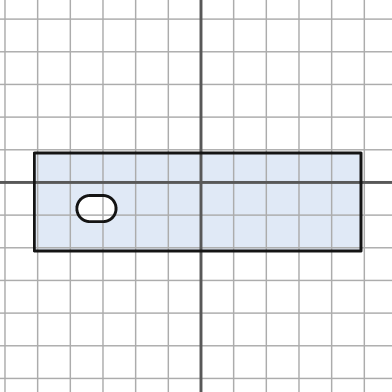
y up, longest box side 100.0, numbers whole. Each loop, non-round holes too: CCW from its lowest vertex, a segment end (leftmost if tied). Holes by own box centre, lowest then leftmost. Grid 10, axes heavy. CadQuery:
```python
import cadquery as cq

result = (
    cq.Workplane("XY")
    .moveTo(-51.0, -21.0)
    .lineTo(49.0, -21.0)
    .lineTo(49.0, 9.0)
    .lineTo(-51.0, 9.0)
    .close()
    .moveTo(-34.0, -12.0)
    .lineTo(-30.0, -12.0)
    .threePointArc((-26.0, -8.0), (-30.0, -4.0))
    .lineTo(-34.0, -4.0)
    .threePointArc((-38.0, -8.0), (-34.0, -12.0))
    .close()
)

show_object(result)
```